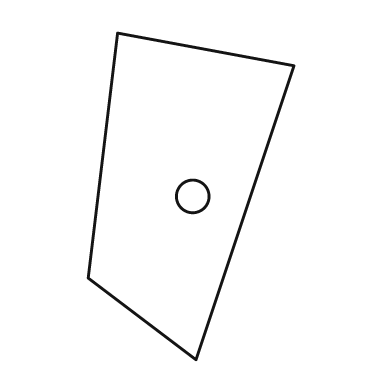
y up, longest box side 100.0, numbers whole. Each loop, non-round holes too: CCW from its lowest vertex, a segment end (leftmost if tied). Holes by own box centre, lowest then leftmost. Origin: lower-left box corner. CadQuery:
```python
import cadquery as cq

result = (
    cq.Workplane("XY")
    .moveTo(33.0, 0.0)
    .lineTo(63.0, 90.0)
    .lineTo(9.0, 100.0)
    .lineTo(0.0, 25.0)
    .close()
    .moveTo(32.0, 50.0)
    .circle(5.0)
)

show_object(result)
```